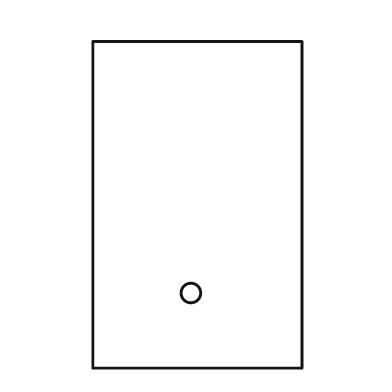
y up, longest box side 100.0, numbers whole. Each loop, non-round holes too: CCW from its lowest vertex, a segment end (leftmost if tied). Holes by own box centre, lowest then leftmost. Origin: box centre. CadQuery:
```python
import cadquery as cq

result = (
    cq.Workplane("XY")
    .moveTo(-32.0, -50.0)
    .lineTo(32.0, -50.0)
    .lineTo(32.0, 50.0)
    .lineTo(-32.0, 50.0)
    .close()
    .moveTo(-2.0, -27.0)
    .circle(3.0)
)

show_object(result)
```